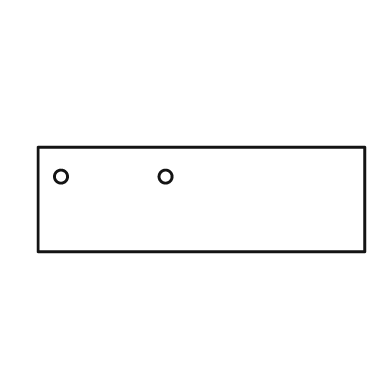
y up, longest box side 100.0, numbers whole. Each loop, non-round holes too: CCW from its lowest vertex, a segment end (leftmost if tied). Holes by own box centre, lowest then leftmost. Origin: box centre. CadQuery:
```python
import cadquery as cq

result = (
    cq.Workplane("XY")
    .moveTo(-50.0, -16.0)
    .lineTo(50.0, -16.0)
    .lineTo(50.0, 16.0)
    .lineTo(-50.0, 16.0)
    .close()
    .moveTo(-43.0, 7.0)
    .circle(2.0)
    .moveTo(-11.0, 7.0)
    .circle(2.0)
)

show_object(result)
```